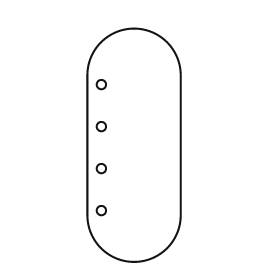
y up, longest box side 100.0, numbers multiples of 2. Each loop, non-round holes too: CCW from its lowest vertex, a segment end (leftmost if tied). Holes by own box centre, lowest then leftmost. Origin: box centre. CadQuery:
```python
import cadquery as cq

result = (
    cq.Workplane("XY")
    .moveTo(-20.0, -30.0)
    .threePointArc((0.0, -50.0), (20.0, -30.0))
    .lineTo(20.0, 30.0)
    .threePointArc((0.0, 50.0), (-20.0, 30.0))
    .close()
    .moveTo(-14.0, -28.0)
    .circle(2.0)
    .moveTo(-14.0, -10.0)
    .circle(2.0)
    .moveTo(-14.0, 8.0)
    .circle(2.0)
    .moveTo(-14.0, 26.0)
    .circle(2.0)
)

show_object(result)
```